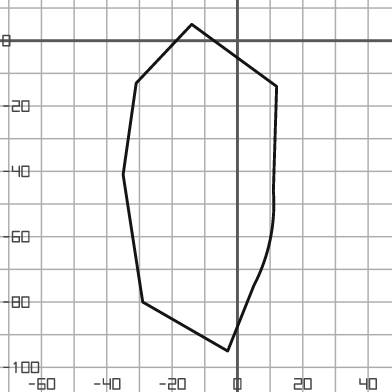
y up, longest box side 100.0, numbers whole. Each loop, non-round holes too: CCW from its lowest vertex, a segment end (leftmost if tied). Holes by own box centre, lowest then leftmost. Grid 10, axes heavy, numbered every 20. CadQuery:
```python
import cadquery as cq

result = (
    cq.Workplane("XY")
    .moveTo(-3.0, -95.0)
    .lineTo(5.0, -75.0)
    .threePointArc((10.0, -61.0), (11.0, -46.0))
    .lineTo(12.0, -14.0)
    .lineTo(-14.0, 5.0)
    .lineTo(-31.0, -13.0)
    .lineTo(-35.0, -41.0)
    .lineTo(-29.0, -80.0)
    .close()
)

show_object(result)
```